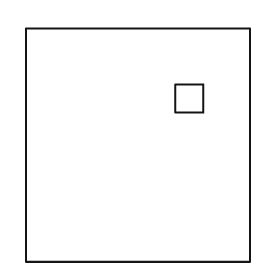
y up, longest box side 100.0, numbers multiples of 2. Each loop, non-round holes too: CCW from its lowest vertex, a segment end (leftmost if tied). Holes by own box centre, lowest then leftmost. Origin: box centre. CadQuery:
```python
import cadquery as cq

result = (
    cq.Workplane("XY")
    .moveTo(-48.0, -50.0)
    .lineTo(48.0, -50.0)
    .lineTo(48.0, 50.0)
    .lineTo(-48.0, 50.0)
    .close()
    .moveTo(16.0, 14.0)
    .lineTo(28.0, 14.0)
    .lineTo(28.0, 26.0)
    .lineTo(16.0, 26.0)
    .close()
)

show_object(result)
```